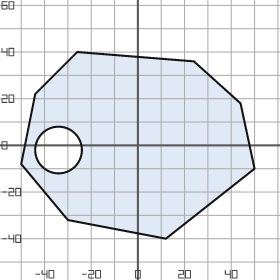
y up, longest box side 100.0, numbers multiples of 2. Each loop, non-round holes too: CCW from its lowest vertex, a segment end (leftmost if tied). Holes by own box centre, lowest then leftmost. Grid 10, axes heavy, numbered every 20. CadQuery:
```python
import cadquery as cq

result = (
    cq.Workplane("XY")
    .moveTo(12.0, -40.0)
    .lineTo(50.0, -10.0)
    .lineTo(44.0, 18.0)
    .lineTo(24.0, 36.0)
    .lineTo(-26.0, 40.0)
    .lineTo(-44.0, 22.0)
    .lineTo(-50.0, -8.0)
    .lineTo(-30.0, -32.0)
    .close()
    .moveTo(-34.0, -2.0)
    .circle(10.0)
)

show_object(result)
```